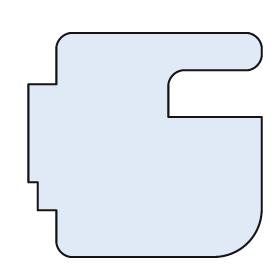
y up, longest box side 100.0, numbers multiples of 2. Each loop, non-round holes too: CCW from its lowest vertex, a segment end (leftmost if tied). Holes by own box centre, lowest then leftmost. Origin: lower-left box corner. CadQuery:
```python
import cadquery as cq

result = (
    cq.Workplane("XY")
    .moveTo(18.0, 0.0)
    .lineTo(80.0, 0.0)
    .threePointArc((94.0, 6.0), (100.0, 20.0))
    .lineTo(100.0, 60.0)
    .lineTo(60.0, 60.0)
    .lineTo(60.0, 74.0)
    .threePointArc((62.0, 78.0), (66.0, 80.0))
    .lineTo(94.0, 80.0)
    .threePointArc((98.0, 82.0), (100.0, 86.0))
    .lineTo(100.0, 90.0)
    .threePointArc((98.0, 94.0), (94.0, 96.0))
    .lineTo(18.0, 96.0)
    .threePointArc((14.0, 94.0), (12.0, 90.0))
    .lineTo(12.0, 74.0)
    .lineTo(0.0, 74.0)
    .lineTo(0.0, 32.0)
    .lineTo(4.0, 32.0)
    .lineTo(4.0, 20.0)
    .lineTo(12.0, 20.0)
    .lineTo(12.0, 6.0)
    .threePointArc((14.0, 2.0), (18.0, 0.0))
    .close()
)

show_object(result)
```